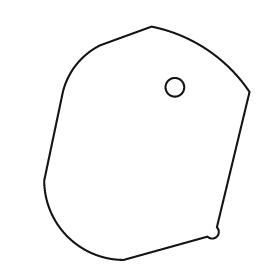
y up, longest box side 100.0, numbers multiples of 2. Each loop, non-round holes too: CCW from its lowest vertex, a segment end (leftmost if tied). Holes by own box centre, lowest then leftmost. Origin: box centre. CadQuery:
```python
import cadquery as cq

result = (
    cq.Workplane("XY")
    .moveTo(-10.0, -50.0)
    .lineTo(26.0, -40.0)
    .threePointArc((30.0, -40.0), (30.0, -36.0))
    .lineTo(44.0, 22.0)
    .threePointArc((26.0, 40.0), (2.0, 50.0))
    .lineTo(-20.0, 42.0)
    .threePointArc((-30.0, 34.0), (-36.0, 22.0))
    .lineTo(-44.0, -16.0)
    .threePointArc((-34.0, -40.0), (-10.0, -50.0))
    .close()
    .moveTo(12.0, 24.0)
    .circle(4.0)
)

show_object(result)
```